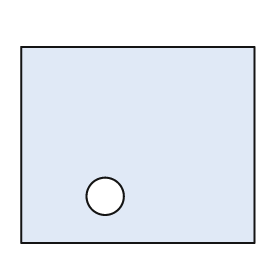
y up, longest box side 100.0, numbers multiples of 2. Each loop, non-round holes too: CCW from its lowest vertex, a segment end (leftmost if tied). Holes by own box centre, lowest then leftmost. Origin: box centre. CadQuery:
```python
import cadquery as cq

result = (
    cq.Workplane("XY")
    .moveTo(-50.0, -42.0)
    .lineTo(50.0, -42.0)
    .lineTo(50.0, 42.0)
    .lineTo(-50.0, 42.0)
    .close()
    .moveTo(-14.0, -22.0)
    .circle(8.0)
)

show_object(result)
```